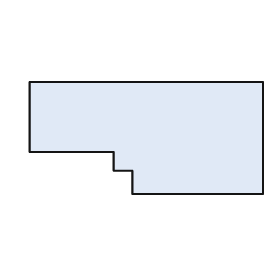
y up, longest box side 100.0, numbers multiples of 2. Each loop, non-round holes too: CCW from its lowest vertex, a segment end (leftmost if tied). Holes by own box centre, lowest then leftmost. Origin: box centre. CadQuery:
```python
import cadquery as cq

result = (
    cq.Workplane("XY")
    .moveTo(-6.0, -24.0)
    .lineTo(50.0, -24.0)
    .lineTo(50.0, 24.0)
    .lineTo(-50.0, 24.0)
    .lineTo(-50.0, -6.0)
    .lineTo(-14.0, -6.0)
    .lineTo(-14.0, -14.0)
    .lineTo(-6.0, -14.0)
    .close()
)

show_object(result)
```